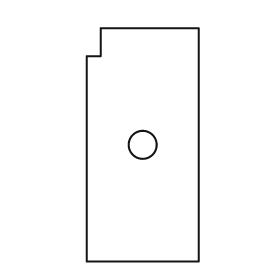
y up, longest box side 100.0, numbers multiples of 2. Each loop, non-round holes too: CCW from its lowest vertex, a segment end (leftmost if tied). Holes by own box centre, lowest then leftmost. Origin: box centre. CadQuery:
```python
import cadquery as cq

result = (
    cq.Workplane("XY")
    .moveTo(-24.0, -50.0)
    .lineTo(24.0, -50.0)
    .lineTo(24.0, 50.0)
    .lineTo(-18.0, 50.0)
    .lineTo(-18.0, 38.0)
    .lineTo(-24.0, 38.0)
    .close()
    .moveTo(0.0, 0.0)
    .circle(6.0)
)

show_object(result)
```